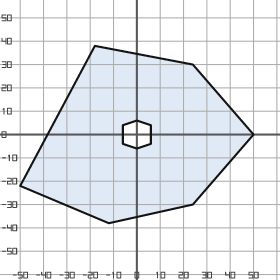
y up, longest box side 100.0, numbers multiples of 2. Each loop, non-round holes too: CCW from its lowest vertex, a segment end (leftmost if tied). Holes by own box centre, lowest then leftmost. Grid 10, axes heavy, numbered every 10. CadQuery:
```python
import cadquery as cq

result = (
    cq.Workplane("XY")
    .moveTo(-12.0, -38.0)
    .lineTo(24.0, -30.0)
    .lineTo(50.0, 0.0)
    .lineTo(24.0, 30.0)
    .lineTo(-18.0, 38.0)
    .lineTo(-50.0, -22.0)
    .close()
    .moveTo(0.0, -6.0)
    .lineTo(6.0, -4.0)
    .lineTo(6.0, 4.0)
    .lineTo(0.0, 6.0)
    .lineTo(-6.0, 4.0)
    .lineTo(-6.0, -4.0)
    .close()
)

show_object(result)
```